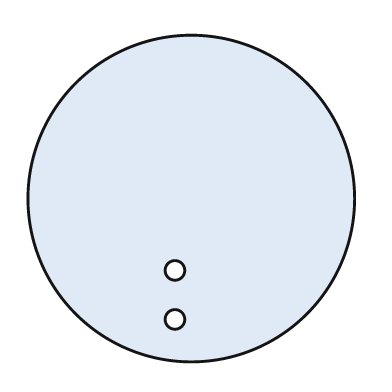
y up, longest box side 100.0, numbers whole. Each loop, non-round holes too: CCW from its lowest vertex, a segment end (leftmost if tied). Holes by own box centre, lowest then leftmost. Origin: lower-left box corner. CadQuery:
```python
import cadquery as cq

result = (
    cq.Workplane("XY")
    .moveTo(50.0, 50.0)
    .circle(50.0)
    .moveTo(45.0, 13.0)
    .circle(3.0)
    .moveTo(45.0, 28.0)
    .circle(3.0)
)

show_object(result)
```